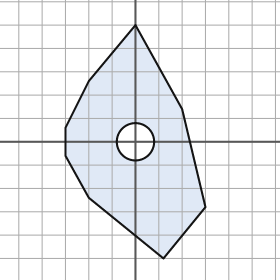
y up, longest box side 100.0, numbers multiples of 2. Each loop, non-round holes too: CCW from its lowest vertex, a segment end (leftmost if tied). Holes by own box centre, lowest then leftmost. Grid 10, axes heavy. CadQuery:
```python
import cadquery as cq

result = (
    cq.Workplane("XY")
    .moveTo(12.0, -50.0)
    .lineTo(30.0, -28.0)
    .lineTo(20.0, 14.0)
    .lineTo(0.0, 50.0)
    .lineTo(-20.0, 26.0)
    .lineTo(-30.0, 6.0)
    .lineTo(-30.0, -6.0)
    .lineTo(-20.0, -24.0)
    .close()
    .moveTo(0.0, 0.0)
    .circle(8.0)
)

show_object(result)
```